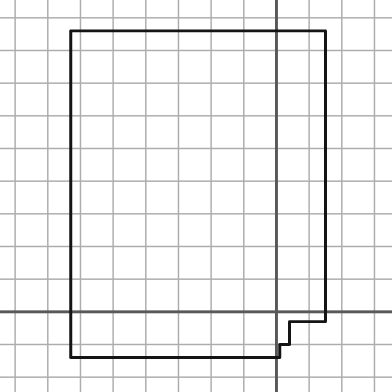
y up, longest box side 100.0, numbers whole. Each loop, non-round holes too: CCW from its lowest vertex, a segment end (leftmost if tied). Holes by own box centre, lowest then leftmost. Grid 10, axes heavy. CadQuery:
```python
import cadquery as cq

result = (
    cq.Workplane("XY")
    .moveTo(-63.0, -14.0)
    .lineTo(1.0, -14.0)
    .lineTo(1.0, -10.0)
    .lineTo(4.0, -10.0)
    .lineTo(4.0, -3.0)
    .lineTo(15.0, -3.0)
    .lineTo(15.0, 86.0)
    .lineTo(-63.0, 86.0)
    .close()
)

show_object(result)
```